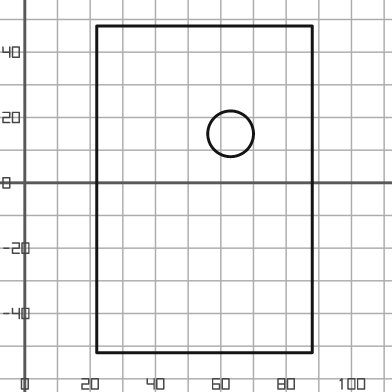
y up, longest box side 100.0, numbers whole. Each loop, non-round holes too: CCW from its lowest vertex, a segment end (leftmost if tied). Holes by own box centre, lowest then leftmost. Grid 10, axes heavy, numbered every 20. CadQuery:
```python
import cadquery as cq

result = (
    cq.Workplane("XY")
    .moveTo(22.0, -52.0)
    .lineTo(88.0, -52.0)
    .lineTo(88.0, 48.0)
    .lineTo(22.0, 48.0)
    .close()
    .moveTo(63.0, 15.0)
    .circle(7.0)
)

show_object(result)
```